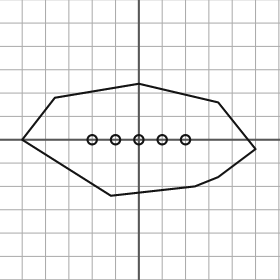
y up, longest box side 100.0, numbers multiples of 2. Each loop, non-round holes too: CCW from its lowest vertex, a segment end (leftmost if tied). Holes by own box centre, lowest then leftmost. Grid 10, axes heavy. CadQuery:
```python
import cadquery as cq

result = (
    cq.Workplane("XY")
    .moveTo(-12.0, -24.0)
    .lineTo(24.0, -20.0)
    .lineTo(34.0, -16.0)
    .lineTo(50.0, -4.0)
    .lineTo(34.0, 16.0)
    .lineTo(0.0, 24.0)
    .lineTo(-36.0, 18.0)
    .lineTo(-50.0, 0.0)
    .close()
    .moveTo(-20.0, 0.0)
    .circle(2.0)
    .moveTo(-10.0, 0.0)
    .circle(2.0)
    .moveTo(0.0, 0.0)
    .circle(2.0)
    .moveTo(10.0, 0.0)
    .circle(2.0)
    .moveTo(20.0, 0.0)
    .circle(2.0)
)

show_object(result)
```